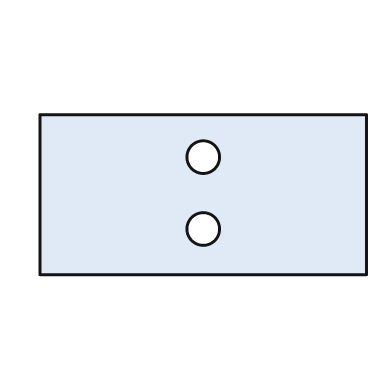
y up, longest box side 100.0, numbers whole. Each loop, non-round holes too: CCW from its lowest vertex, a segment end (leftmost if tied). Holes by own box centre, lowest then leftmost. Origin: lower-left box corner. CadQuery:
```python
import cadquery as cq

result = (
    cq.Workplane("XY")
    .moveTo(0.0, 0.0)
    .lineTo(100.0, 0.0)
    .lineTo(100.0, 49.0)
    .lineTo(0.0, 49.0)
    .close()
    .moveTo(50.0, 14.0)
    .circle(5.0)
    .moveTo(50.0, 36.0)
    .circle(5.0)
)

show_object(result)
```